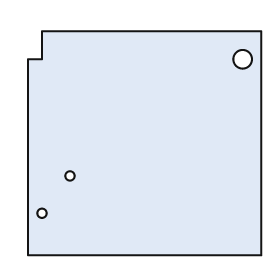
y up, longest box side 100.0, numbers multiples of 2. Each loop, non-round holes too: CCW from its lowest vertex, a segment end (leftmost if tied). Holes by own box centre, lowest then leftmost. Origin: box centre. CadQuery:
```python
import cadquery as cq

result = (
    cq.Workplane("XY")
    .moveTo(-50.0, -48.0)
    .lineTo(50.0, -48.0)
    .lineTo(50.0, 48.0)
    .lineTo(-44.0, 48.0)
    .lineTo(-44.0, 36.0)
    .lineTo(-50.0, 36.0)
    .close()
    .moveTo(-44.0, -30.0)
    .circle(2.0)
    .moveTo(-32.0, -14.0)
    .circle(2.0)
    .moveTo(42.0, 36.0)
    .circle(4.0)
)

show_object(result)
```